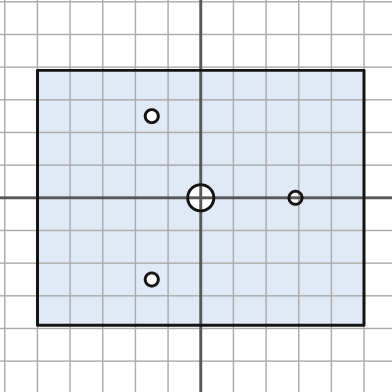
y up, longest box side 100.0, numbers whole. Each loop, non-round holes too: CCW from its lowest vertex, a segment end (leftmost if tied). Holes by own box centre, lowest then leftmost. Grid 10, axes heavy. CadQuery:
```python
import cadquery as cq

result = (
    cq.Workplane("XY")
    .moveTo(-50.0, -39.0)
    .lineTo(50.0, -39.0)
    .lineTo(50.0, 39.0)
    .lineTo(-50.0, 39.0)
    .close()
    .moveTo(-15.0, -25.0)
    .circle(2.0)
    .moveTo(0.0, 0.0)
    .circle(4.0)
    .moveTo(29.0, 0.0)
    .circle(2.0)
    .moveTo(-15.0, 25.0)
    .circle(2.0)
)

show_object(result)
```